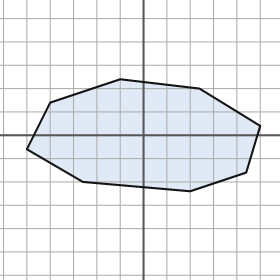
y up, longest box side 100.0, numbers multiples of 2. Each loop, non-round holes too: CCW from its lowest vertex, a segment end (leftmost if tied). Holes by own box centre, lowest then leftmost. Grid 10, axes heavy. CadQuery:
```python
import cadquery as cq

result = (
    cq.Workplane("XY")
    .moveTo(20.0, -24.0)
    .lineTo(44.0, -16.0)
    .lineTo(50.0, 4.0)
    .lineTo(24.0, 20.0)
    .lineTo(-10.0, 24.0)
    .lineTo(-40.0, 14.0)
    .lineTo(-50.0, -6.0)
    .lineTo(-26.0, -20.0)
    .close()
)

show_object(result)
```